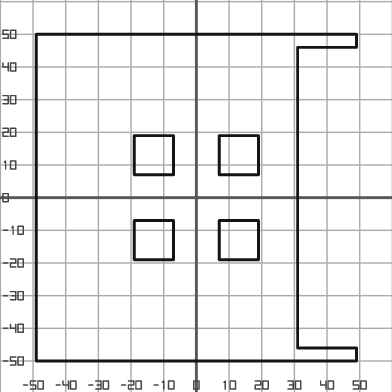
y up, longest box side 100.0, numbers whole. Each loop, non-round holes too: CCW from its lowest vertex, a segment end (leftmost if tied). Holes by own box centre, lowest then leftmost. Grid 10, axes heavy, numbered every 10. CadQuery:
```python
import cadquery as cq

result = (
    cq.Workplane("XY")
    .moveTo(-49.0, -50.0)
    .lineTo(49.0, -50.0)
    .lineTo(49.0, -46.0)
    .lineTo(31.0, -46.0)
    .lineTo(31.0, 46.0)
    .lineTo(49.0, 46.0)
    .lineTo(49.0, 50.0)
    .lineTo(-49.0, 50.0)
    .close()
    .moveTo(-19.0, -19.0)
    .lineTo(-7.0, -19.0)
    .lineTo(-7.0, -7.0)
    .lineTo(-19.0, -7.0)
    .close()
    .moveTo(7.0, -19.0)
    .lineTo(19.0, -19.0)
    .lineTo(19.0, -7.0)
    .lineTo(7.0, -7.0)
    .close()
    .moveTo(-19.0, 7.0)
    .lineTo(-7.0, 7.0)
    .lineTo(-7.0, 19.0)
    .lineTo(-19.0, 19.0)
    .close()
    .moveTo(7.0, 7.0)
    .lineTo(19.0, 7.0)
    .lineTo(19.0, 19.0)
    .lineTo(7.0, 19.0)
    .close()
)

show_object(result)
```